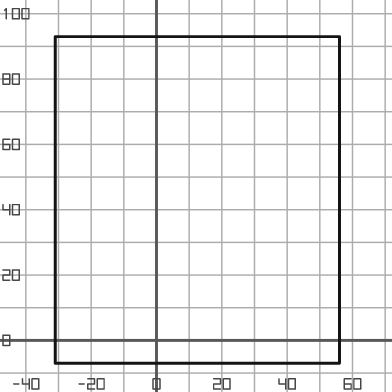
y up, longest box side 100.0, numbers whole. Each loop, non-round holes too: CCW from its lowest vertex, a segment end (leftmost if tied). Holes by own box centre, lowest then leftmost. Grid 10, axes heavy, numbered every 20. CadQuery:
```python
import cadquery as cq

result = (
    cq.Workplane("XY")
    .moveTo(-31.0, -7.0)
    .lineTo(56.0, -7.0)
    .lineTo(56.0, 93.0)
    .lineTo(-31.0, 93.0)
    .close()
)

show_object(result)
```